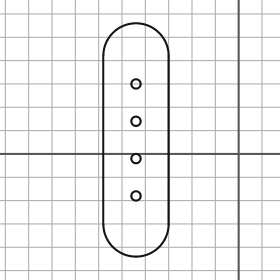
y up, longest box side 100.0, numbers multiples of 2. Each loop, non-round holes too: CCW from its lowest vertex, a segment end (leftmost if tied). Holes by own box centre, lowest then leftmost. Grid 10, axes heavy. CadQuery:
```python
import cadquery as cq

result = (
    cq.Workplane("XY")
    .moveTo(-58.0, -30.0)
    .threePointArc((-44.0, -44.0), (-30.0, -30.0))
    .lineTo(-30.0, 42.0)
    .threePointArc((-44.0, 56.0), (-58.0, 42.0))
    .close()
    .moveTo(-44.0, -18.0)
    .circle(2.0)
    .moveTo(-44.0, -2.0)
    .circle(2.0)
    .moveTo(-44.0, 14.0)
    .circle(2.0)
    .moveTo(-44.0, 30.0)
    .circle(2.0)
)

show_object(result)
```